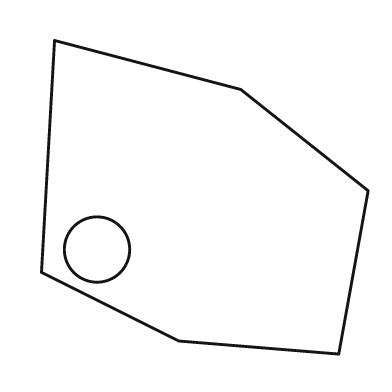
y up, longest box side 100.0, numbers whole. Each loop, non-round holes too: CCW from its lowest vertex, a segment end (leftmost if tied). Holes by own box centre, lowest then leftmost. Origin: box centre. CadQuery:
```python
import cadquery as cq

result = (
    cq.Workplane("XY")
    .moveTo(41.0, -48.0)
    .lineTo(50.0, 2.0)
    .lineTo(11.0, 33.0)
    .lineTo(-46.0, 48.0)
    .lineTo(-50.0, -23.0)
    .lineTo(-8.0, -44.0)
    .close()
    .moveTo(-33.0, -16.0)
    .circle(10.0)
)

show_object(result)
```